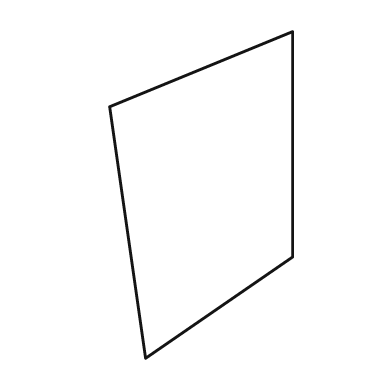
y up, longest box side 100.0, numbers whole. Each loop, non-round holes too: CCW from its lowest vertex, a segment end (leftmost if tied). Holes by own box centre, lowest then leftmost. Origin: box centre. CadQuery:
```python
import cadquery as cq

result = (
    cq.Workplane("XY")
    .moveTo(-17.0, -50.0)
    .lineTo(28.0, -19.0)
    .lineTo(28.0, 50.0)
    .lineTo(-28.0, 27.0)
    .close()
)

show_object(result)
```